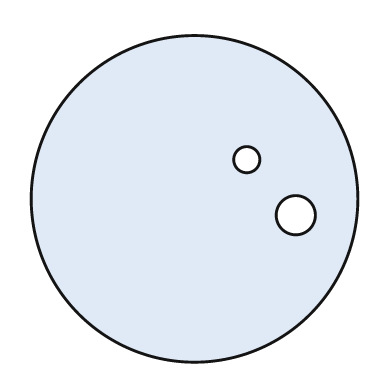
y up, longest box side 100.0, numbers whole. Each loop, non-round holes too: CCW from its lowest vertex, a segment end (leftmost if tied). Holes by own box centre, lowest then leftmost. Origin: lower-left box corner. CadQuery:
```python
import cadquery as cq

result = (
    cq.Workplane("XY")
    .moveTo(50.0, 50.0)
    .circle(50.0)
    .moveTo(81.0, 45.0)
    .circle(6.0)
    .moveTo(66.0, 62.0)
    .circle(4.0)
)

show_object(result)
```